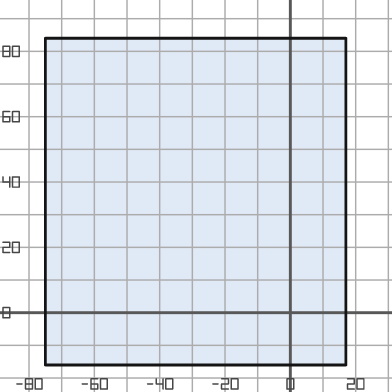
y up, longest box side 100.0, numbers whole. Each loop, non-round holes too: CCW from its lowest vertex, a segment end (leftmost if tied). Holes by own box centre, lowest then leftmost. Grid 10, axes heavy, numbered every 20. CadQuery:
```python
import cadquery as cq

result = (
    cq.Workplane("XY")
    .moveTo(-75.0, -16.0)
    .lineTo(17.0, -16.0)
    .lineTo(17.0, 84.0)
    .lineTo(-75.0, 84.0)
    .close()
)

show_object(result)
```